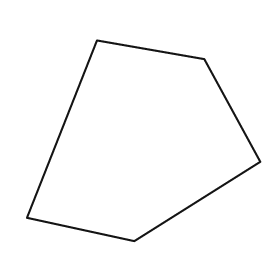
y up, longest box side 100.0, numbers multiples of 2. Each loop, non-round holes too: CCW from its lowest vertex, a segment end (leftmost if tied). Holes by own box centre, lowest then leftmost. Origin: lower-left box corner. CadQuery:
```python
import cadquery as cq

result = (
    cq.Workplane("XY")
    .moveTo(46.0, 0.0)
    .lineTo(100.0, 34.0)
    .lineTo(76.0, 78.0)
    .lineTo(30.0, 86.0)
    .lineTo(0.0, 10.0)
    .close()
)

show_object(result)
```